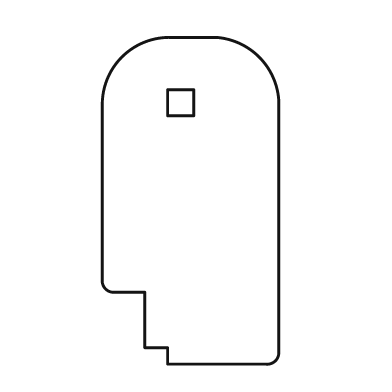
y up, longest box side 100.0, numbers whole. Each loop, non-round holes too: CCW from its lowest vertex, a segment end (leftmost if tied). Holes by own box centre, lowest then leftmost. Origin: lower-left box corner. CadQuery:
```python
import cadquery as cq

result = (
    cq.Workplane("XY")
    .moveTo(20.0, 0.0)
    .lineTo(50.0, 0.0)
    .threePointArc((53.0, 1.0), (54.0, 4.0))
    .lineTo(54.0, 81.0)
    .threePointArc((48.0, 94.0), (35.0, 100.0))
    .lineTo(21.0, 100.0)
    .threePointArc((6.0, 94.0), (0.0, 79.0))
    .lineTo(0.0, 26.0)
    .threePointArc((1.0, 23.0), (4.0, 22.0))
    .lineTo(13.0, 22.0)
    .lineTo(13.0, 5.0)
    .lineTo(20.0, 5.0)
    .close()
    .moveTo(20.0, 76.0)
    .lineTo(28.0, 76.0)
    .lineTo(28.0, 84.0)
    .lineTo(20.0, 84.0)
    .close()
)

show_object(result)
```